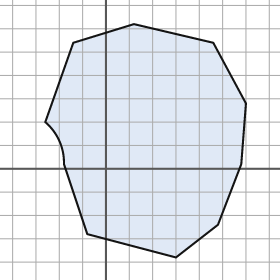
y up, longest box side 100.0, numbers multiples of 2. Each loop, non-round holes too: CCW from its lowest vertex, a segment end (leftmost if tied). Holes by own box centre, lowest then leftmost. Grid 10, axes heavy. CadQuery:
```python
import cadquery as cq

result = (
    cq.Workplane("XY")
    .moveTo(30.0, -38.0)
    .lineTo(48.0, -24.0)
    .lineTo(58.0, 2.0)
    .lineTo(60.0, 28.0)
    .lineTo(46.0, 54.0)
    .lineTo(12.0, 62.0)
    .lineTo(-14.0, 54.0)
    .lineTo(-26.0, 20.0)
    .threePointArc((-20.0, 12.0), (-18.0, 2.0))
    .lineTo(-8.0, -28.0)
    .close()
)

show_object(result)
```